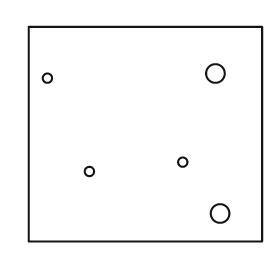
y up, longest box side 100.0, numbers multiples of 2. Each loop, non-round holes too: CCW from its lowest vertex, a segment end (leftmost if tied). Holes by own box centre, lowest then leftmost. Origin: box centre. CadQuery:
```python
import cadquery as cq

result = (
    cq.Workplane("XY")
    .moveTo(-50.0, -46.0)
    .lineTo(50.0, -46.0)
    .lineTo(50.0, 46.0)
    .lineTo(-50.0, 46.0)
    .close()
    .moveTo(32.0, -34.0)
    .circle(4.0)
    .moveTo(-24.0, -16.0)
    .circle(2.0)
    .moveTo(16.0, -12.0)
    .circle(2.0)
    .moveTo(-42.0, 24.0)
    .circle(2.0)
    .moveTo(30.0, 26.0)
    .circle(4.0)
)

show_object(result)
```